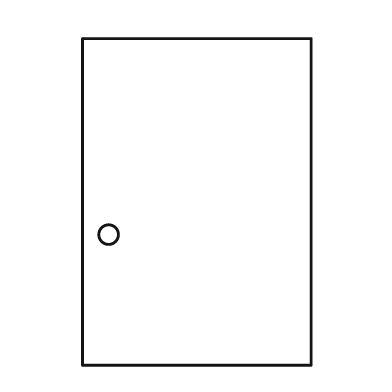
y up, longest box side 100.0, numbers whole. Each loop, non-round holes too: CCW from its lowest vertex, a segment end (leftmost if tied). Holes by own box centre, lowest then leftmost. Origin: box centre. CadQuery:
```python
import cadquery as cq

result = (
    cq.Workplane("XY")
    .moveTo(-35.0, -50.0)
    .lineTo(35.0, -50.0)
    .lineTo(35.0, 50.0)
    .lineTo(-35.0, 50.0)
    .close()
    .moveTo(-27.0, -10.0)
    .circle(3.0)
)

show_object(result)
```